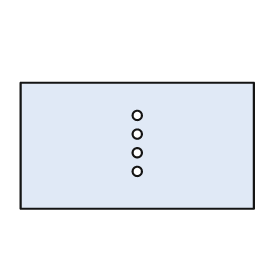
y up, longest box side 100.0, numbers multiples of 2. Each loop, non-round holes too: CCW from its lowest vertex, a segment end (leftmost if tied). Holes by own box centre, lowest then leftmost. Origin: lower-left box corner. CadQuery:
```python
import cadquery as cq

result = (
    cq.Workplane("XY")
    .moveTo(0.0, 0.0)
    .lineTo(100.0, 0.0)
    .lineTo(100.0, 54.0)
    .lineTo(0.0, 54.0)
    .close()
    .moveTo(50.0, 16.0)
    .circle(2.0)
    .moveTo(50.0, 24.0)
    .circle(2.0)
    .moveTo(50.0, 32.0)
    .circle(2.0)
    .moveTo(50.0, 40.0)
    .circle(2.0)
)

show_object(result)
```